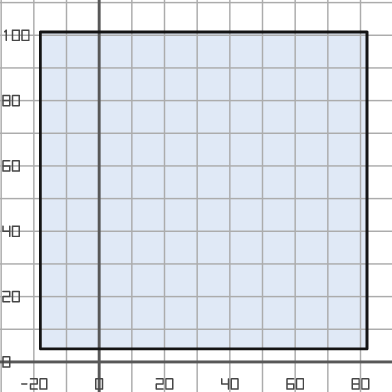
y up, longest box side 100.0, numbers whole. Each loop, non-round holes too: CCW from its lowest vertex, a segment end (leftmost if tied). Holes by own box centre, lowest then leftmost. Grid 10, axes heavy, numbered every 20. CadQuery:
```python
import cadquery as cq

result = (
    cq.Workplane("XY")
    .moveTo(-18.0, 4.0)
    .lineTo(82.0, 4.0)
    .lineTo(82.0, 101.0)
    .lineTo(-18.0, 101.0)
    .close()
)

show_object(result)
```